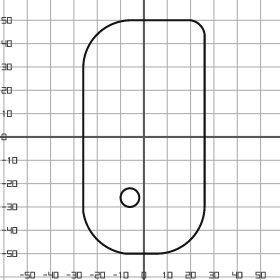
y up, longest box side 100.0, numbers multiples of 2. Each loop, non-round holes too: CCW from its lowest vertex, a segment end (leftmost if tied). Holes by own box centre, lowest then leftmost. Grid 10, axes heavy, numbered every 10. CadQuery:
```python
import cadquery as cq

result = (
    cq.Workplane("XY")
    .moveTo(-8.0, -50.0)
    .lineTo(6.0, -50.0)
    .threePointArc((20.0, -44.0), (26.0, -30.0))
    .lineTo(26.0, 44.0)
    .threePointArc((24.0, 48.0), (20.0, 50.0))
    .lineTo(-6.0, 50.0)
    .threePointArc((-20.0, 44.0), (-26.0, 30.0))
    .lineTo(-26.0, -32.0)
    .threePointArc((-20.0, -44.0), (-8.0, -50.0))
    .close()
    .moveTo(-6.0, -26.0)
    .circle(4.0)
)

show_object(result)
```